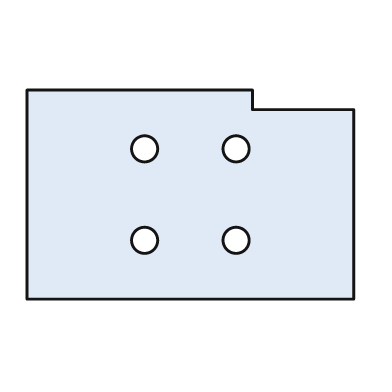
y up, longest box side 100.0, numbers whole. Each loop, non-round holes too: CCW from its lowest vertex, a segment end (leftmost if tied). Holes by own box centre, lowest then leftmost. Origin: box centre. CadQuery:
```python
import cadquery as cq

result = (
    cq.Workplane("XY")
    .moveTo(-50.0, -32.0)
    .lineTo(50.0, -32.0)
    .lineTo(50.0, 26.0)
    .lineTo(19.0, 26.0)
    .lineTo(19.0, 32.0)
    .lineTo(-50.0, 32.0)
    .close()
    .moveTo(-14.0, -14.0)
    .circle(4.0)
    .moveTo(14.0, -14.0)
    .circle(4.0)
    .moveTo(-14.0, 14.0)
    .circle(4.0)
    .moveTo(14.0, 14.0)
    .circle(4.0)
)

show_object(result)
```